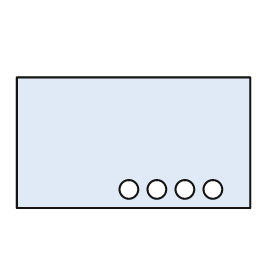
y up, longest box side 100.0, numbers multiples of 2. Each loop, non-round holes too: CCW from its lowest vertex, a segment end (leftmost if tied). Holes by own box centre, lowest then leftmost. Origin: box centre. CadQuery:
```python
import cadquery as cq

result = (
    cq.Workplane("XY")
    .moveTo(-50.0, -28.0)
    .lineTo(50.0, -28.0)
    .lineTo(50.0, 28.0)
    .lineTo(-50.0, 28.0)
    .close()
    .moveTo(-2.0, -20.0)
    .circle(4.0)
    .moveTo(10.0, -20.0)
    .circle(4.0)
    .moveTo(22.0, -20.0)
    .circle(4.0)
    .moveTo(34.0, -20.0)
    .circle(4.0)
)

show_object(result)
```